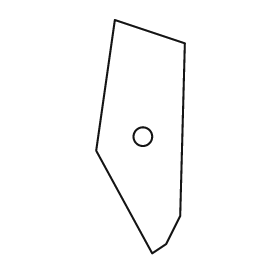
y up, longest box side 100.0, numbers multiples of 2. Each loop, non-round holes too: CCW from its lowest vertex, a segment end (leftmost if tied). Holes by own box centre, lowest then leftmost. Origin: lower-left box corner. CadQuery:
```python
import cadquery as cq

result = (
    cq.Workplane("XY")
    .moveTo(24.0, 0.0)
    .lineTo(30.0, 4.0)
    .lineTo(36.0, 16.0)
    .lineTo(38.0, 90.0)
    .lineTo(8.0, 100.0)
    .lineTo(0.0, 44.0)
    .close()
    .moveTo(20.0, 50.0)
    .circle(4.0)
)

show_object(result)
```